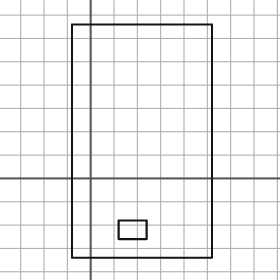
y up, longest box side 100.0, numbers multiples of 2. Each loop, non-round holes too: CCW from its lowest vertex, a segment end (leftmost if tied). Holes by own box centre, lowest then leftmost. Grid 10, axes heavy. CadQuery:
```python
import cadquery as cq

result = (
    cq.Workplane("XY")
    .moveTo(-8.0, -34.0)
    .lineTo(52.0, -34.0)
    .lineTo(52.0, 66.0)
    .lineTo(-8.0, 66.0)
    .close()
    .moveTo(12.0, -26.0)
    .lineTo(24.0, -26.0)
    .lineTo(24.0, -18.0)
    .lineTo(12.0, -18.0)
    .close()
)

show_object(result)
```